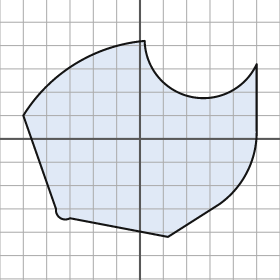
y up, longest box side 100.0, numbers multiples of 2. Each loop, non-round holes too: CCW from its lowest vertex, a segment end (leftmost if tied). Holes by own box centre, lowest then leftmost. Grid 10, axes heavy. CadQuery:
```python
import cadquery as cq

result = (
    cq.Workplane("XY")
    .moveTo(12.0, -42.0)
    .lineTo(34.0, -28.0)
    .threePointArc((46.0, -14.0), (50.0, 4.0))
    .lineTo(50.0, 32.0)
    .threePointArc((22.0, 18.0), (2.0, 42.0))
    .threePointArc((-28.0, 32.0), (-50.0, 10.0))
    .lineTo(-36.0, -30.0)
    .threePointArc((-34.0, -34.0), (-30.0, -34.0))
    .close()
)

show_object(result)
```